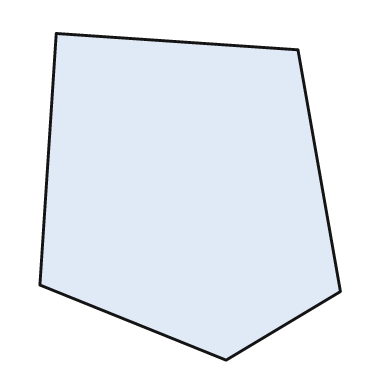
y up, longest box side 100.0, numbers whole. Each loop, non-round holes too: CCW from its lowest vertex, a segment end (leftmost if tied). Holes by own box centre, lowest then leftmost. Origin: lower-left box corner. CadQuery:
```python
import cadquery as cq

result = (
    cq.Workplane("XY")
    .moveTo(57.0, 0.0)
    .lineTo(92.0, 21.0)
    .lineTo(79.0, 95.0)
    .lineTo(5.0, 100.0)
    .lineTo(0.0, 23.0)
    .close()
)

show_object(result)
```